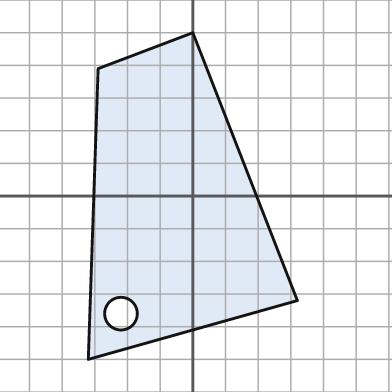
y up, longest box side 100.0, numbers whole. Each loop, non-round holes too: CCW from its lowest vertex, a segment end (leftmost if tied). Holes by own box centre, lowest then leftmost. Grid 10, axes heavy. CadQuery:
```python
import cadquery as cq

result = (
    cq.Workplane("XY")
    .moveTo(-32.0, -50.0)
    .lineTo(32.0, -32.0)
    .lineTo(0.0, 50.0)
    .lineTo(-29.0, 39.0)
    .close()
    .moveTo(-22.0, -36.0)
    .circle(5.0)
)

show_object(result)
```